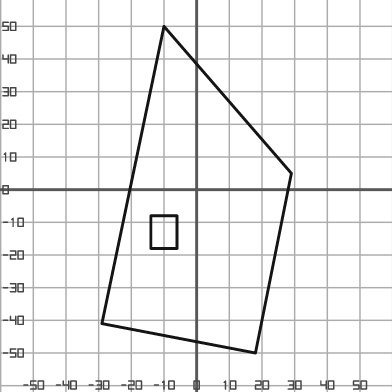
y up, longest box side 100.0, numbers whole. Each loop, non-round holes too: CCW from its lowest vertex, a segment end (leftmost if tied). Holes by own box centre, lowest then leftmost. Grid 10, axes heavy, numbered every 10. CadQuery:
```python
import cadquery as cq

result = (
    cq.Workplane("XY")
    .moveTo(18.0, -50.0)
    .lineTo(29.0, 5.0)
    .lineTo(-10.0, 50.0)
    .lineTo(-29.0, -41.0)
    .close()
    .moveTo(-14.0, -18.0)
    .lineTo(-6.0, -18.0)
    .lineTo(-6.0, -8.0)
    .lineTo(-14.0, -8.0)
    .close()
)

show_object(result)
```